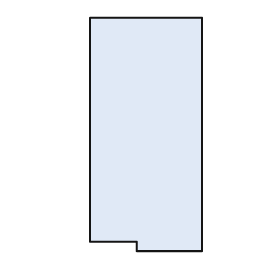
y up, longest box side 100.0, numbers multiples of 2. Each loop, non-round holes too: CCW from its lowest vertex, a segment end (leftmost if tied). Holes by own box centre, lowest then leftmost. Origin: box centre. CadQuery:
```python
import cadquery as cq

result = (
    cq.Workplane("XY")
    .moveTo(-4.0, -50.0)
    .lineTo(24.0, -50.0)
    .lineTo(24.0, 50.0)
    .lineTo(-24.0, 50.0)
    .lineTo(-24.0, -46.0)
    .lineTo(-4.0, -46.0)
    .close()
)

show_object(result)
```